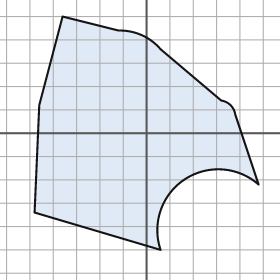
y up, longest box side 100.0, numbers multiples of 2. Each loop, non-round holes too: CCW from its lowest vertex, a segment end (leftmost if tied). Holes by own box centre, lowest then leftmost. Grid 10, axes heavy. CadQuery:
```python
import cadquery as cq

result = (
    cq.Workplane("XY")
    .moveTo(6.0, -50.0)
    .threePointArc((16.0, -20.0), (48.0, -22.0))
    .lineTo(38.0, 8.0)
    .threePointArc((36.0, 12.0), (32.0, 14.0))
    .lineTo(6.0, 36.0)
    .threePointArc((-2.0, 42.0), (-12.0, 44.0))
    .lineTo(-36.0, 50.0)
    .lineTo(-46.0, 12.0)
    .lineTo(-48.0, -34.0)
    .close()
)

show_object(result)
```